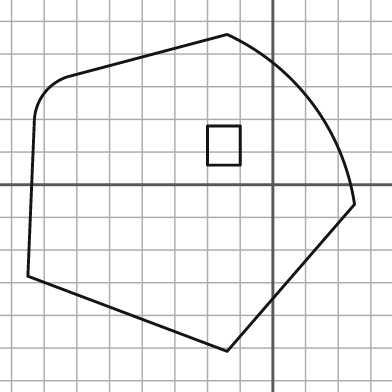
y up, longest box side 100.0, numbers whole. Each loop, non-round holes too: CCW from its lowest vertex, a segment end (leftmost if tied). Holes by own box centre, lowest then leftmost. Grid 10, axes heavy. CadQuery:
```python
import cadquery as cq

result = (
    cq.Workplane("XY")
    .moveTo(-14.0, -51.0)
    .lineTo(25.0, -6.0)
    .threePointArc((12.0, 25.0), (-14.0, 46.0))
    .lineTo(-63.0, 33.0)
    .threePointArc((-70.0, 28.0), (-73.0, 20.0))
    .lineTo(-75.0, -28.0)
    .close()
    .moveTo(-20.0, 6.0)
    .lineTo(-10.0, 6.0)
    .lineTo(-10.0, 18.0)
    .lineTo(-20.0, 18.0)
    .close()
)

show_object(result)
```